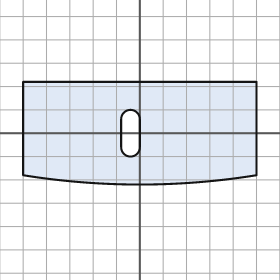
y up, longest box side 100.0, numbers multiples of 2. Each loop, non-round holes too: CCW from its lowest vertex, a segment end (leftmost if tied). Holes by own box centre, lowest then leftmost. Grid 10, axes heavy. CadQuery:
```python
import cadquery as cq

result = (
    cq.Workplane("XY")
    .moveTo(-50.0, -18.0)
    .threePointArc((0.0, -22.0), (50.0, -18.0))
    .lineTo(50.0, 22.0)
    .lineTo(-50.0, 22.0)
    .close()
    .moveTo(-8.0, -6.0)
    .threePointArc((-4.0, -10.0), (0.0, -6.0))
    .lineTo(0.0, 6.0)
    .threePointArc((-4.0, 10.0), (-8.0, 6.0))
    .close()
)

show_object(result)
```